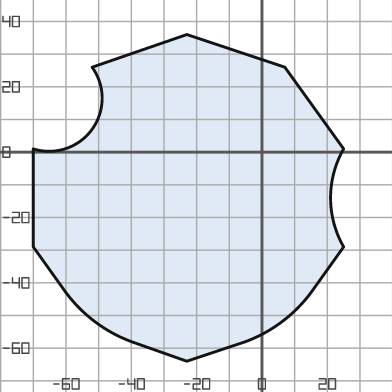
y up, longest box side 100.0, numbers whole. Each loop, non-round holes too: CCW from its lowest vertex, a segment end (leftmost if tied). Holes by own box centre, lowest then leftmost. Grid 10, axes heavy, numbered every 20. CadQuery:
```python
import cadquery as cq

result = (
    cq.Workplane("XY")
    .moveTo(-23.0, -64.0)
    .lineTo(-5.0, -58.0)
    .threePointArc((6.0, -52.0), (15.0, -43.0))
    .lineTo(25.0, -29.0)
    .threePointArc((21.0, -14.0), (25.0, 1.0))
    .lineTo(7.0, 26.0)
    .lineTo(-23.0, 36.0)
    .lineTo(-52.0, 26.0)
    .threePointArc((-52.0, 7.0), (-70.0, 1.0))
    .lineTo(-70.0, -29.0)
    .lineTo(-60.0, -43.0)
    .threePointArc((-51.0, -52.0), (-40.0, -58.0))
    .close()
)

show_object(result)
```